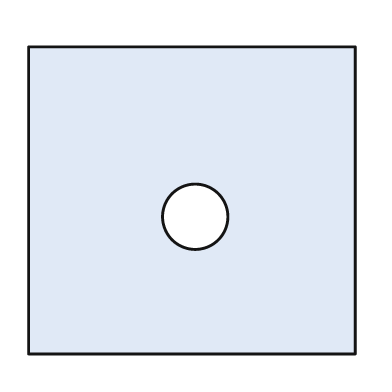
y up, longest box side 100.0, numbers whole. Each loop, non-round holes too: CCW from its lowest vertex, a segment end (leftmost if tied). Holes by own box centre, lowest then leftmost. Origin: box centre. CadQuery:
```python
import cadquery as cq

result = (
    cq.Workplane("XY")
    .moveTo(-50.0, -47.0)
    .lineTo(50.0, -47.0)
    .lineTo(50.0, 47.0)
    .lineTo(-50.0, 47.0)
    .close()
    .moveTo(1.0, -5.0)
    .circle(10.0)
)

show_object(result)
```